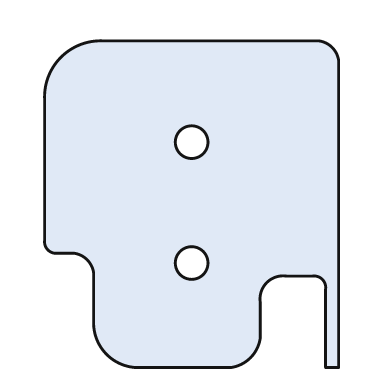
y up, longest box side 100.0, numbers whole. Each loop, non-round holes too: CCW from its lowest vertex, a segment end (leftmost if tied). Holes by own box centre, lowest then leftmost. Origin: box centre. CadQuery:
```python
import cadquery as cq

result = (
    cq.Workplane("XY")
    .moveTo(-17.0, -50.0)
    .lineTo(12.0, -50.0)
    .threePointArc((18.0, -47.0), (21.0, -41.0))
    .lineTo(21.0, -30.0)
    .threePointArc((23.0, -24.0), (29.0, -22.0))
    .lineTo(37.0, -22.0)
    .threePointArc((40.0, -23.0), (41.0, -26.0))
    .lineTo(41.0, -50.0)
    .lineTo(45.0, -50.0)
    .lineTo(45.0, 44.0)
    .threePointArc((43.0, 48.0), (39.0, 50.0))
    .lineTo(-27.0, 50.0)
    .threePointArc((-40.0, 45.0), (-45.0, 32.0))
    .lineTo(-45.0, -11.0)
    .threePointArc((-44.0, -14.0), (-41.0, -15.0))
    .lineTo(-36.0, -15.0)
    .threePointArc((-32.0, -17.0), (-30.0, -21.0))
    .lineTo(-30.0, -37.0)
    .threePointArc((-26.0, -46.0), (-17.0, -50.0))
    .close()
    .moveTo(0.0, -18.0)
    .circle(5.0)
    .moveTo(0.0, 19.0)
    .circle(5.0)
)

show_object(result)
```